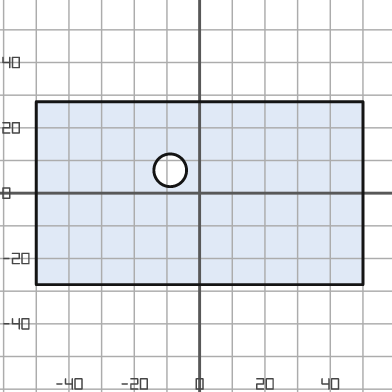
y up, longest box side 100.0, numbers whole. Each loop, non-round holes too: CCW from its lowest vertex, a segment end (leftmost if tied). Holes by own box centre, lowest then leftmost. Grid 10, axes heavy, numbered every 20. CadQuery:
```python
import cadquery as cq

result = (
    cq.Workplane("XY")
    .moveTo(-50.0, -28.0)
    .lineTo(50.0, -28.0)
    .lineTo(50.0, 28.0)
    .lineTo(-50.0, 28.0)
    .close()
    .moveTo(-9.0, 7.0)
    .circle(5.0)
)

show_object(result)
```